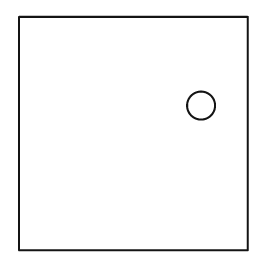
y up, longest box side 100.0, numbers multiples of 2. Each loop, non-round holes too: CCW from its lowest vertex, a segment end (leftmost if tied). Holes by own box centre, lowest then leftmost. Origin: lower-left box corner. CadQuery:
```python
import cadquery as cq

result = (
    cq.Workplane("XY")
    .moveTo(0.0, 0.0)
    .lineTo(98.0, 0.0)
    .lineTo(98.0, 100.0)
    .lineTo(0.0, 100.0)
    .close()
    .moveTo(78.0, 62.0)
    .circle(6.0)
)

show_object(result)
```